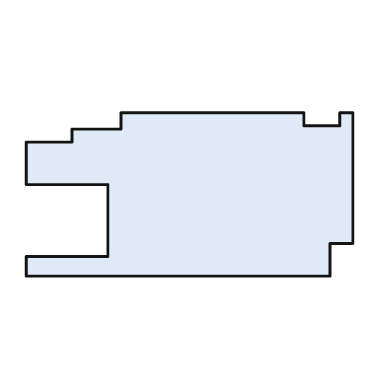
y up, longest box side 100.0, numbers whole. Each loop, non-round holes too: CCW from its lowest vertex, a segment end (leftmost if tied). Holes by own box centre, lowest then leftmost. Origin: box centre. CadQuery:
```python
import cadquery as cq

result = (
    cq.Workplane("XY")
    .moveTo(-50.0, -25.0)
    .lineTo(43.0, -25.0)
    .lineTo(43.0, -15.0)
    .lineTo(50.0, -15.0)
    .lineTo(50.0, 25.0)
    .lineTo(46.0, 25.0)
    .lineTo(46.0, 21.0)
    .lineTo(35.0, 21.0)
    .lineTo(35.0, 25.0)
    .lineTo(-21.0, 25.0)
    .lineTo(-21.0, 20.0)
    .lineTo(-36.0, 20.0)
    .lineTo(-36.0, 16.0)
    .lineTo(-50.0, 16.0)
    .lineTo(-50.0, 3.0)
    .lineTo(-25.0, 3.0)
    .lineTo(-25.0, -19.0)
    .lineTo(-50.0, -19.0)
    .close()
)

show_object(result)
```